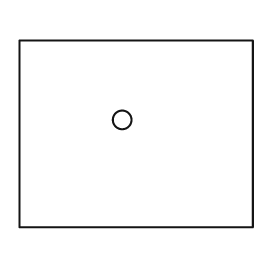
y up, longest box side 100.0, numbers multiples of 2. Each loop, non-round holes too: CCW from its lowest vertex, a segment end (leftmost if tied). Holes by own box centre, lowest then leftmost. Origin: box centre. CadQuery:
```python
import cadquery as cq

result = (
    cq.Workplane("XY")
    .moveTo(-50.0, -40.0)
    .lineTo(50.0, -40.0)
    .lineTo(50.0, 40.0)
    .lineTo(-50.0, 40.0)
    .close()
    .moveTo(-6.0, 6.0)
    .circle(4.0)
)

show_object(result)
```